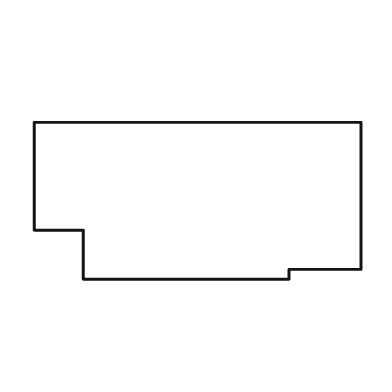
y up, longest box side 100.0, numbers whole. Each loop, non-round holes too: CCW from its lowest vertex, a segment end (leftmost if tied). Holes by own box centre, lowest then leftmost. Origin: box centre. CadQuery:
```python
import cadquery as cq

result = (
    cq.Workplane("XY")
    .moveTo(-35.0, -24.0)
    .lineTo(28.0, -24.0)
    .lineTo(28.0, -21.0)
    .lineTo(50.0, -21.0)
    .lineTo(50.0, 24.0)
    .lineTo(-50.0, 24.0)
    .lineTo(-50.0, -9.0)
    .lineTo(-35.0, -9.0)
    .close()
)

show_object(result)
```